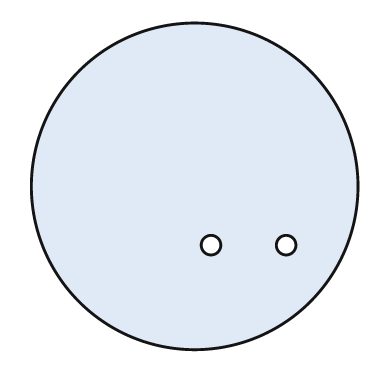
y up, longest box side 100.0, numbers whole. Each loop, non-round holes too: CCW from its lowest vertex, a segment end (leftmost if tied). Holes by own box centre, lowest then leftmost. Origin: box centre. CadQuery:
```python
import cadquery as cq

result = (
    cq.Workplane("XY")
    .moveTo(0.0, 0.0)
    .circle(50.0)
    .moveTo(5.0, -18.0)
    .circle(3.0)
    .moveTo(28.0, -18.0)
    .circle(3.0)
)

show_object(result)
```